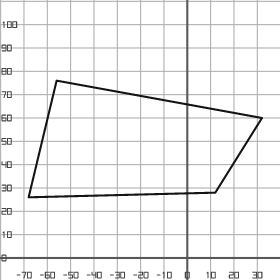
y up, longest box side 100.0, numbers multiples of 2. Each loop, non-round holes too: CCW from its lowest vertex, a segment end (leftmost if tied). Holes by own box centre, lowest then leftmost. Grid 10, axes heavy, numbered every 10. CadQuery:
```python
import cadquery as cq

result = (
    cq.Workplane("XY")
    .moveTo(-68.0, 26.0)
    .lineTo(12.0, 28.0)
    .lineTo(32.0, 60.0)
    .lineTo(-56.0, 76.0)
    .close()
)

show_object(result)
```